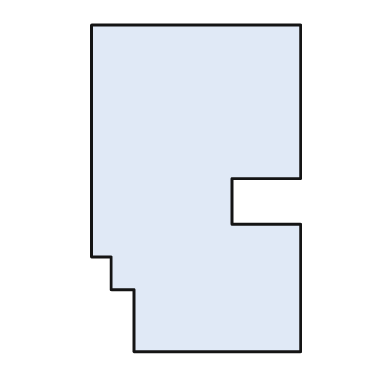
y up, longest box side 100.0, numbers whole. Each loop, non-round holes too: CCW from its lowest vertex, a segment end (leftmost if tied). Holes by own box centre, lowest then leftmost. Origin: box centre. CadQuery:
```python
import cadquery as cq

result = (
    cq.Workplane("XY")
    .moveTo(-19.0, -50.0)
    .lineTo(32.0, -50.0)
    .lineTo(32.0, -11.0)
    .lineTo(11.0, -11.0)
    .lineTo(11.0, 3.0)
    .lineTo(32.0, 3.0)
    .lineTo(32.0, 50.0)
    .lineTo(-32.0, 50.0)
    .lineTo(-32.0, -21.0)
    .lineTo(-26.0, -21.0)
    .lineTo(-26.0, -31.0)
    .lineTo(-19.0, -31.0)
    .close()
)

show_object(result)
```